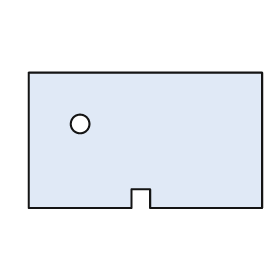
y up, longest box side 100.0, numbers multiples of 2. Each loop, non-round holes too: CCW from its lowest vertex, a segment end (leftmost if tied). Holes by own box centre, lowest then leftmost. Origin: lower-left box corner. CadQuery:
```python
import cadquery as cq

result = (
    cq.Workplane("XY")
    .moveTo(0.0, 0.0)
    .lineTo(44.0, 0.0)
    .lineTo(44.0, 8.0)
    .lineTo(52.0, 8.0)
    .lineTo(52.0, 0.0)
    .lineTo(100.0, 0.0)
    .lineTo(100.0, 58.0)
    .lineTo(0.0, 58.0)
    .close()
    .moveTo(22.0, 36.0)
    .circle(4.0)
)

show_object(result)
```